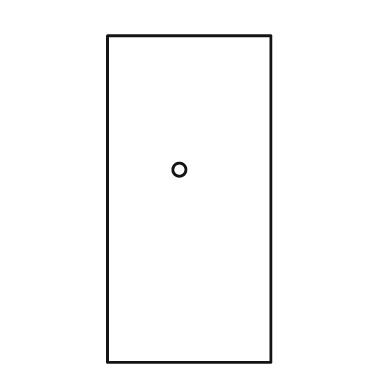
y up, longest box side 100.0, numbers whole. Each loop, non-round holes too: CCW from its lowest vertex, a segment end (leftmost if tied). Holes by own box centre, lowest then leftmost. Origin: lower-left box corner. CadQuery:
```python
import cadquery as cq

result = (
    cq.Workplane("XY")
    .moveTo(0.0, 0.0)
    .lineTo(50.0, 0.0)
    .lineTo(50.0, 100.0)
    .lineTo(0.0, 100.0)
    .close()
    .moveTo(22.0, 59.0)
    .circle(2.0)
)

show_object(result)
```